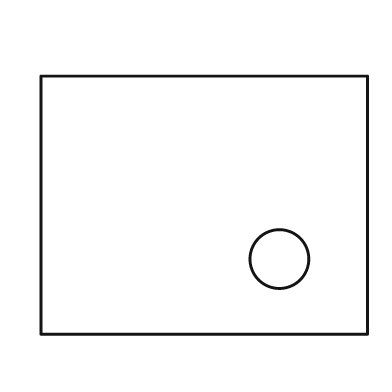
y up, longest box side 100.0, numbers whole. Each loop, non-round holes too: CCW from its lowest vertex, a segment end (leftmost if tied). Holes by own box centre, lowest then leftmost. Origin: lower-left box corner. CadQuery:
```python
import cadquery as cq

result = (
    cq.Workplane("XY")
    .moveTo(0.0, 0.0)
    .lineTo(100.0, 0.0)
    .lineTo(100.0, 79.0)
    .lineTo(0.0, 79.0)
    .close()
    .moveTo(73.0, 23.0)
    .circle(9.0)
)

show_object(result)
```